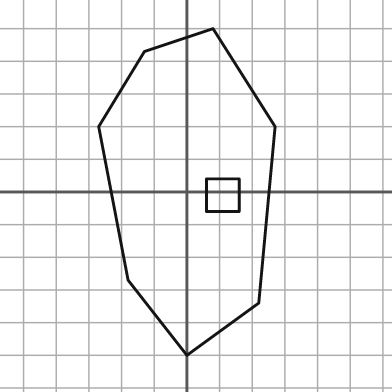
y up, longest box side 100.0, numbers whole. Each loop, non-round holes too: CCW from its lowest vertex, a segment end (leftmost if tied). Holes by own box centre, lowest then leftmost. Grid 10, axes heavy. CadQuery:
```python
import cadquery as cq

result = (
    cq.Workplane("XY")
    .moveTo(0.0, -50.0)
    .lineTo(22.0, -34.0)
    .lineTo(27.0, 20.0)
    .lineTo(8.0, 50.0)
    .lineTo(-13.0, 43.0)
    .lineTo(-27.0, 20.0)
    .lineTo(-18.0, -27.0)
    .close()
    .moveTo(6.0, -6.0)
    .lineTo(16.0, -6.0)
    .lineTo(16.0, 4.0)
    .lineTo(6.0, 4.0)
    .close()
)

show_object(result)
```